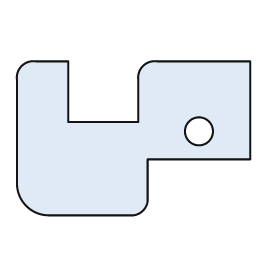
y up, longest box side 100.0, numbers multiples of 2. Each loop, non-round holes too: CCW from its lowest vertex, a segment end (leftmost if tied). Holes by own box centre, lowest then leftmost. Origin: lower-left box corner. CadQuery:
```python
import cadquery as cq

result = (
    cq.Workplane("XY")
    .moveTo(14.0, 0.0)
    .lineTo(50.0, 0.0)
    .threePointArc((54.0, 2.0), (56.0, 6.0))
    .lineTo(56.0, 24.0)
    .lineTo(100.0, 24.0)
    .lineTo(100.0, 66.0)
    .lineTo(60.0, 66.0)
    .threePointArc((54.0, 64.0), (52.0, 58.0))
    .lineTo(52.0, 40.0)
    .lineTo(22.0, 40.0)
    .lineTo(22.0, 66.0)
    .lineTo(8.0, 66.0)
    .threePointArc((2.0, 64.0), (0.0, 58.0))
    .lineTo(0.0, 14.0)
    .threePointArc((4.0, 4.0), (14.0, 0.0))
    .close()
    .moveTo(78.0, 36.0)
    .circle(6.0)
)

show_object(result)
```